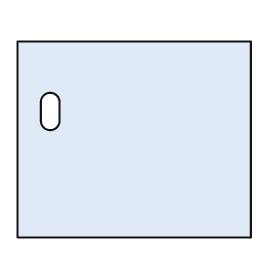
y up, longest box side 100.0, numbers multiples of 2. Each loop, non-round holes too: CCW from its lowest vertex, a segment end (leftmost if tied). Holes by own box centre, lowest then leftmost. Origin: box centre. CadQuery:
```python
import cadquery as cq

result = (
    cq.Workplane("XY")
    .moveTo(-50.0, -42.0)
    .lineTo(50.0, -42.0)
    .lineTo(50.0, 42.0)
    .lineTo(-50.0, 42.0)
    .close()
    .moveTo(-40.0, 8.0)
    .threePointArc((-36.0, 4.0), (-32.0, 8.0))
    .lineTo(-32.0, 16.0)
    .threePointArc((-36.0, 20.0), (-40.0, 16.0))
    .close()
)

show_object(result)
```